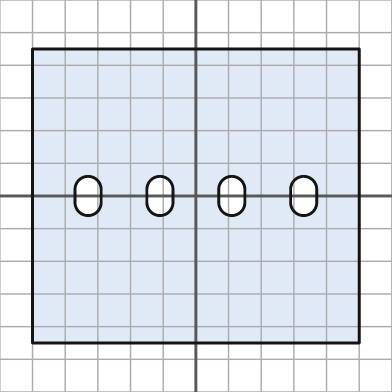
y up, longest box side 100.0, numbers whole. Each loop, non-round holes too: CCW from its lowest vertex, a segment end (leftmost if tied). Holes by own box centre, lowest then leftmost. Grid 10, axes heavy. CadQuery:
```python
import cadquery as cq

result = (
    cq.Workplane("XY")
    .moveTo(-50.0, -45.0)
    .lineTo(50.0, -45.0)
    .lineTo(50.0, 45.0)
    .lineTo(-50.0, 45.0)
    .close()
    .moveTo(-37.0, -2.0)
    .threePointArc((-33.0, -6.0), (-29.0, -2.0))
    .lineTo(-29.0, 2.0)
    .threePointArc((-33.0, 6.0), (-37.0, 2.0))
    .close()
    .moveTo(-15.0, -2.0)
    .threePointArc((-11.0, -6.0), (-7.0, -2.0))
    .lineTo(-7.0, 2.0)
    .threePointArc((-11.0, 6.0), (-15.0, 2.0))
    .close()
    .moveTo(7.0, -2.0)
    .threePointArc((11.0, -6.0), (15.0, -2.0))
    .lineTo(15.0, 2.0)
    .threePointArc((11.0, 6.0), (7.0, 2.0))
    .close()
    .moveTo(29.0, -2.0)
    .threePointArc((33.0, -6.0), (37.0, -2.0))
    .lineTo(37.0, 2.0)
    .threePointArc((33.0, 6.0), (29.0, 2.0))
    .close()
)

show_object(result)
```